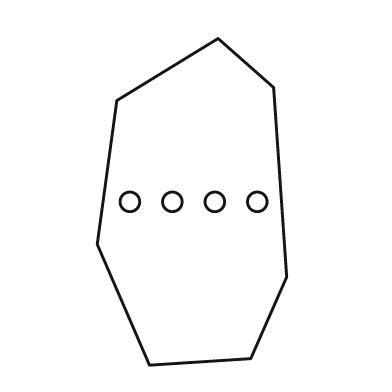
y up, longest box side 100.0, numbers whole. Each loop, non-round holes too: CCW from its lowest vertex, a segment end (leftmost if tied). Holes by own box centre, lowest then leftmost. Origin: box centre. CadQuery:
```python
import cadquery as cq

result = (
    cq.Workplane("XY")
    .moveTo(-13.0, -50.0)
    .lineTo(18.0, -48.0)
    .lineTo(29.0, -23.0)
    .lineTo(25.0, 35.0)
    .lineTo(8.0, 50.0)
    .lineTo(-23.0, 31.0)
    .lineTo(-29.0, -13.0)
    .close()
    .moveTo(-19.0, 0.0)
    .circle(3.0)
    .moveTo(-6.0, 0.0)
    .circle(3.0)
    .moveTo(7.0, 0.0)
    .circle(3.0)
    .moveTo(20.0, 0.0)
    .circle(3.0)
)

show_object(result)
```